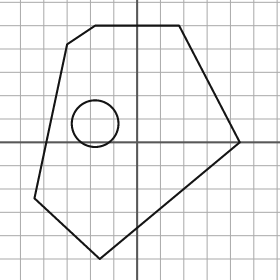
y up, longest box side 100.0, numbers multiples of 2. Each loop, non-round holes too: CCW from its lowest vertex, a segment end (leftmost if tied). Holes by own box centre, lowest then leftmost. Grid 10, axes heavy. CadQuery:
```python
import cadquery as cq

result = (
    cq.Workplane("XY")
    .moveTo(-16.0, -50.0)
    .lineTo(44.0, 0.0)
    .lineTo(18.0, 50.0)
    .lineTo(-18.0, 50.0)
    .lineTo(-30.0, 42.0)
    .lineTo(-44.0, -24.0)
    .close()
    .moveTo(-18.0, 8.0)
    .circle(10.0)
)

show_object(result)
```